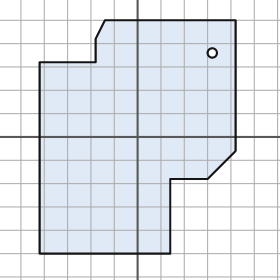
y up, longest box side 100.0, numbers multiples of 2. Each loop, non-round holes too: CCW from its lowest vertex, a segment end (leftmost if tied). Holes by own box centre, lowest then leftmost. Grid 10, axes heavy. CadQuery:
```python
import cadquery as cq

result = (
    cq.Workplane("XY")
    .moveTo(-42.0, -50.0)
    .lineTo(14.0, -50.0)
    .lineTo(14.0, -18.0)
    .lineTo(30.0, -18.0)
    .lineTo(42.0, -6.0)
    .lineTo(42.0, 50.0)
    .lineTo(-14.0, 50.0)
    .lineTo(-18.0, 42.0)
    .lineTo(-18.0, 32.0)
    .lineTo(-42.0, 32.0)
    .close()
    .moveTo(32.0, 36.0)
    .circle(2.0)
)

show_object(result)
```